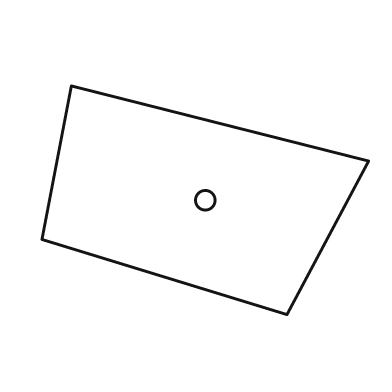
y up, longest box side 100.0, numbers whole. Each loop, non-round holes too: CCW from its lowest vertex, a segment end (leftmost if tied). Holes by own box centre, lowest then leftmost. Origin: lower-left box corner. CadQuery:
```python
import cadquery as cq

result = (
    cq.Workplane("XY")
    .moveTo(75.0, 0.0)
    .lineTo(100.0, 47.0)
    .lineTo(9.0, 70.0)
    .lineTo(0.0, 23.0)
    .close()
    .moveTo(50.0, 35.0)
    .circle(3.0)
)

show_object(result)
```